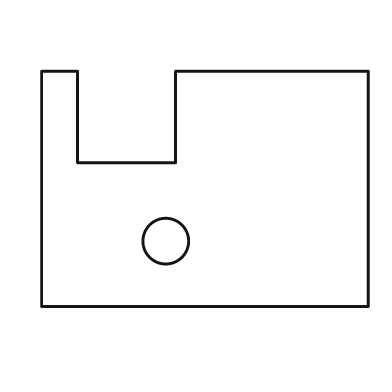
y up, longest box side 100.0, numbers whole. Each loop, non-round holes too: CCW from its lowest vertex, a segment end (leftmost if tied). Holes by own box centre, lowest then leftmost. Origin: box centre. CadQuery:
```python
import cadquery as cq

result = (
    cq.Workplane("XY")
    .moveTo(-50.0, -36.0)
    .lineTo(50.0, -36.0)
    .lineTo(50.0, 36.0)
    .lineTo(-9.0, 36.0)
    .lineTo(-9.0, 8.0)
    .lineTo(-39.0, 8.0)
    .lineTo(-39.0, 36.0)
    .lineTo(-50.0, 36.0)
    .close()
    .moveTo(-12.0, -16.0)
    .circle(7.0)
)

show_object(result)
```